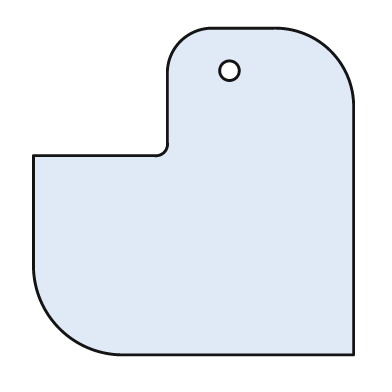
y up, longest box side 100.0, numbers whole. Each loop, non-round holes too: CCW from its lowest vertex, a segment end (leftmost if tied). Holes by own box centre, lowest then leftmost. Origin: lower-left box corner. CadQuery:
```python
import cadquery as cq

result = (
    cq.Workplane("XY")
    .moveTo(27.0, 0.0)
    .lineTo(98.0, 0.0)
    .lineTo(98.0, 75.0)
    .threePointArc((91.0, 93.0), (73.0, 100.0))
    .lineTo(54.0, 100.0)
    .threePointArc((45.0, 96.0), (41.0, 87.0))
    .lineTo(41.0, 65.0)
    .threePointArc((40.0, 62.0), (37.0, 61.0))
    .lineTo(0.0, 61.0)
    .lineTo(0.0, 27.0)
    .threePointArc((8.0, 8.0), (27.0, 0.0))
    .close()
    .moveTo(60.0, 87.0)
    .circle(3.0)
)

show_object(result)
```